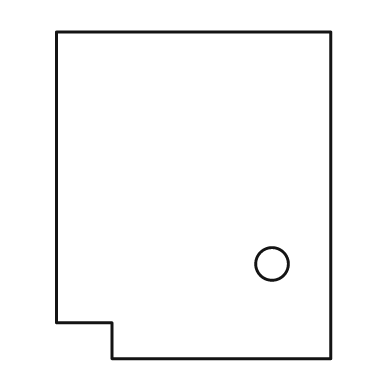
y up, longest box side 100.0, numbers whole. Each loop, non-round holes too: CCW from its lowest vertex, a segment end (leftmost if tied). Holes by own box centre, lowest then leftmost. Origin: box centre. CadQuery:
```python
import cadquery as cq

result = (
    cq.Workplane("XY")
    .moveTo(-25.0, -50.0)
    .lineTo(42.0, -50.0)
    .lineTo(42.0, 50.0)
    .lineTo(-42.0, 50.0)
    .lineTo(-42.0, -39.0)
    .lineTo(-25.0, -39.0)
    .close()
    .moveTo(24.0, -21.0)
    .circle(5.0)
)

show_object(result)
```